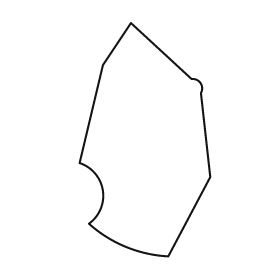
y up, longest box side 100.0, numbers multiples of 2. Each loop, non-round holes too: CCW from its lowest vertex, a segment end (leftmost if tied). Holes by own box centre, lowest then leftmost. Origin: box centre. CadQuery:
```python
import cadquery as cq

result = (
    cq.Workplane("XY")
    .moveTo(10.0, -50.0)
    .lineTo(28.0, -16.0)
    .lineTo(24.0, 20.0)
    .threePointArc((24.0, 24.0), (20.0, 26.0))
    .lineTo(-6.0, 50.0)
    .lineTo(-18.0, 32.0)
    .lineTo(-28.0, -10.0)
    .threePointArc((-18.0, -22.0), (-24.0, -36.0))
    .threePointArc((-8.0, -46.0), (10.0, -50.0))
    .close()
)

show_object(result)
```